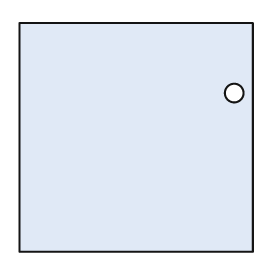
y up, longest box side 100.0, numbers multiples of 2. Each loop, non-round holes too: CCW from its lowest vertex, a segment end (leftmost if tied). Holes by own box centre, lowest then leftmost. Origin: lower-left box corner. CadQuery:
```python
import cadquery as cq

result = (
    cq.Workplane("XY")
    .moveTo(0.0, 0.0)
    .lineTo(100.0, 0.0)
    .lineTo(100.0, 98.0)
    .lineTo(0.0, 98.0)
    .close()
    .moveTo(92.0, 68.0)
    .circle(4.0)
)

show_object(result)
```